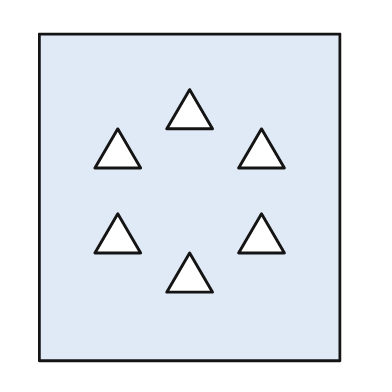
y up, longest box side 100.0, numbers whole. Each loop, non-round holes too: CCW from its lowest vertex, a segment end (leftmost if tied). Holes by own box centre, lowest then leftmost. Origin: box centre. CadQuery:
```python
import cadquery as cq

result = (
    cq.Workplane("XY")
    .moveTo(-46.0, -50.0)
    .lineTo(46.0, -50.0)
    .lineTo(46.0, 50.0)
    .lineTo(-46.0, 50.0)
    .close()
    .moveTo(-7.0, -29.0)
    .lineTo(7.0, -29.0)
    .lineTo(0.0, -17.0)
    .close()
    .moveTo(-29.0, -17.0)
    .lineTo(-15.0, -17.0)
    .lineTo(-22.0, -5.0)
    .close()
    .moveTo(15.0, -17.0)
    .lineTo(29.0, -17.0)
    .lineTo(22.0, -5.0)
    .close()
    .moveTo(-29.0, 9.0)
    .lineTo(-15.0, 9.0)
    .lineTo(-22.0, 21.0)
    .close()
    .moveTo(15.0, 9.0)
    .lineTo(29.0, 9.0)
    .lineTo(22.0, 21.0)
    .close()
    .moveTo(-7.0, 21.0)
    .lineTo(7.0, 21.0)
    .lineTo(0.0, 33.0)
    .close()
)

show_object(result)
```